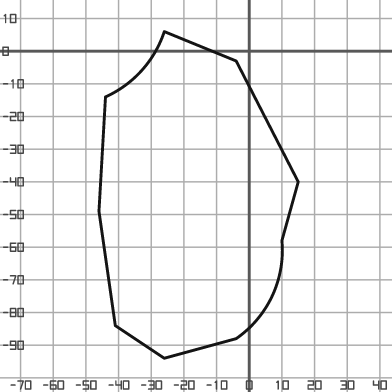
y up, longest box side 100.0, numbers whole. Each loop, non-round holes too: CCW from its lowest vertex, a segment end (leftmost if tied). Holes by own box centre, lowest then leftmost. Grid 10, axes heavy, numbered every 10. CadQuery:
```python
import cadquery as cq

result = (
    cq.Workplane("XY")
    .moveTo(-26.0, -94.0)
    .lineTo(-4.0, -88.0)
    .threePointArc((7.0, -75.0), (10.0, -58.0))
    .lineTo(15.0, -40.0)
    .lineTo(-4.0, -3.0)
    .lineTo(-26.0, 6.0)
    .threePointArc((-33.0, -6.0), (-44.0, -14.0))
    .lineTo(-46.0, -49.0)
    .lineTo(-41.0, -84.0)
    .close()
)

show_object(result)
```